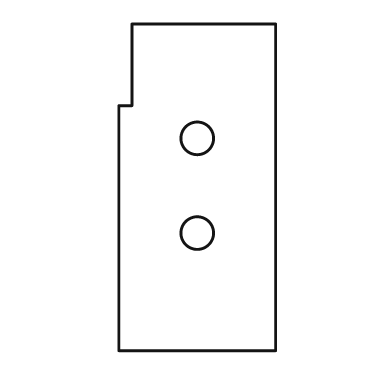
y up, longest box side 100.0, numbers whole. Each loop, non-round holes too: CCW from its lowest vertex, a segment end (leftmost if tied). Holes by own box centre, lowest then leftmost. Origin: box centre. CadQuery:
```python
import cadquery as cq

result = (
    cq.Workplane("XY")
    .moveTo(-24.0, -50.0)
    .lineTo(24.0, -50.0)
    .lineTo(24.0, 50.0)
    .lineTo(-20.0, 50.0)
    .lineTo(-20.0, 25.0)
    .lineTo(-24.0, 25.0)
    .close()
    .moveTo(0.0, -14.0)
    .circle(5.0)
    .moveTo(0.0, 15.0)
    .circle(5.0)
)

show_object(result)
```